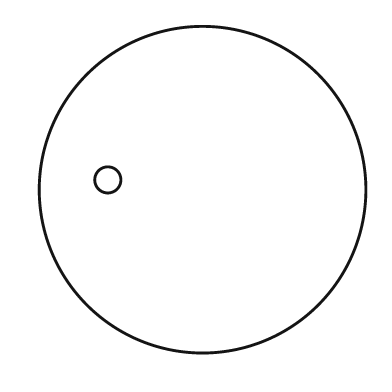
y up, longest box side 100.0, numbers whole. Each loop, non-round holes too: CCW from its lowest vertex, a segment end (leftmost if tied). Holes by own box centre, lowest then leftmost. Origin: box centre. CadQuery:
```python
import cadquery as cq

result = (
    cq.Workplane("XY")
    .moveTo(0.0, 0.0)
    .circle(50.0)
    .moveTo(-29.0, 3.0)
    .circle(4.0)
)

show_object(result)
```